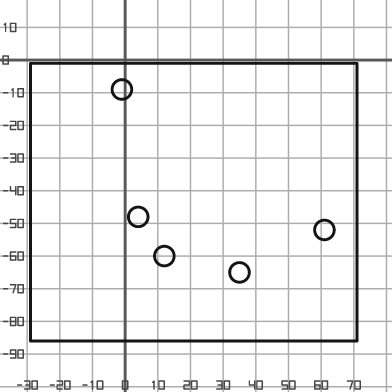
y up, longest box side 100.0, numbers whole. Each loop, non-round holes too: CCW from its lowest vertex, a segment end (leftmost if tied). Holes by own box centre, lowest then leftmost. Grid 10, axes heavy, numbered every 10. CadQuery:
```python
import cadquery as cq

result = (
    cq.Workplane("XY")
    .moveTo(-29.0, -86.0)
    .lineTo(71.0, -86.0)
    .lineTo(71.0, -1.0)
    .lineTo(-29.0, -1.0)
    .close()
    .moveTo(35.0, -65.0)
    .circle(3.0)
    .moveTo(12.0, -60.0)
    .circle(3.0)
    .moveTo(61.0, -52.0)
    .circle(3.0)
    .moveTo(4.0, -48.0)
    .circle(3.0)
    .moveTo(-1.0, -9.0)
    .circle(3.0)
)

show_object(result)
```